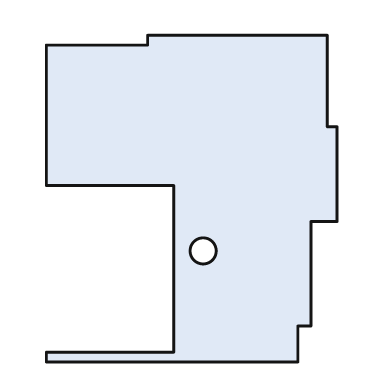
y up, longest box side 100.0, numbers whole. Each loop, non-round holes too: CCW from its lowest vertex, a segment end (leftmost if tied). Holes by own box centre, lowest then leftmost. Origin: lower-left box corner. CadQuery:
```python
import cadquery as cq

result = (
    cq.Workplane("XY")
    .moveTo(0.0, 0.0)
    .lineTo(77.0, 0.0)
    .lineTo(77.0, 11.0)
    .lineTo(81.0, 11.0)
    .lineTo(81.0, 43.0)
    .lineTo(89.0, 43.0)
    .lineTo(89.0, 72.0)
    .lineTo(86.0, 72.0)
    .lineTo(86.0, 100.0)
    .lineTo(31.0, 100.0)
    .lineTo(31.0, 97.0)
    .lineTo(0.0, 97.0)
    .lineTo(0.0, 54.0)
    .lineTo(39.0, 54.0)
    .lineTo(39.0, 3.0)
    .lineTo(0.0, 3.0)
    .close()
    .moveTo(48.0, 34.0)
    .circle(4.0)
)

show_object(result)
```